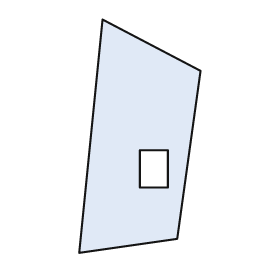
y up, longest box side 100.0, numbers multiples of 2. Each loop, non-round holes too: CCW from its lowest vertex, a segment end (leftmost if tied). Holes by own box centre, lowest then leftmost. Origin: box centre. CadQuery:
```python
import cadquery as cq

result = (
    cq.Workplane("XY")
    .moveTo(-26.0, -50.0)
    .lineTo(16.0, -44.0)
    .lineTo(26.0, 28.0)
    .lineTo(-16.0, 50.0)
    .close()
    .moveTo(0.0, -22.0)
    .lineTo(12.0, -22.0)
    .lineTo(12.0, -6.0)
    .lineTo(0.0, -6.0)
    .close()
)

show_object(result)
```